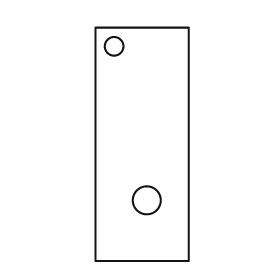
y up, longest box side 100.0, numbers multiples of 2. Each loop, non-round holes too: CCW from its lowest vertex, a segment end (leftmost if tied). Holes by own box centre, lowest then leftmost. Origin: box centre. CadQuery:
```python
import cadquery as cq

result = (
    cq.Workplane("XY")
    .moveTo(-20.0, -50.0)
    .lineTo(20.0, -50.0)
    .lineTo(20.0, 50.0)
    .lineTo(-20.0, 50.0)
    .close()
    .moveTo(2.0, -24.0)
    .circle(6.0)
    .moveTo(-12.0, 42.0)
    .circle(4.0)
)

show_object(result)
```